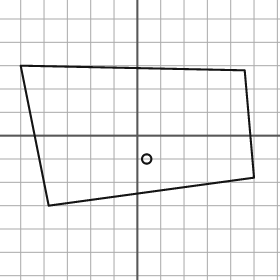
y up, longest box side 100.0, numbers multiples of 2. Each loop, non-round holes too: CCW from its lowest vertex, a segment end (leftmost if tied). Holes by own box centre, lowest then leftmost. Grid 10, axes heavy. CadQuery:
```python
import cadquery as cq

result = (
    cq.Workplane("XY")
    .moveTo(-38.0, -30.0)
    .lineTo(50.0, -18.0)
    .lineTo(46.0, 28.0)
    .lineTo(-50.0, 30.0)
    .close()
    .moveTo(4.0, -10.0)
    .circle(2.0)
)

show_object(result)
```